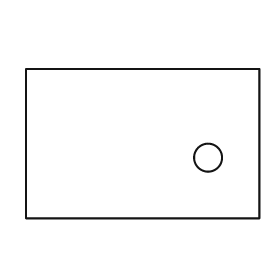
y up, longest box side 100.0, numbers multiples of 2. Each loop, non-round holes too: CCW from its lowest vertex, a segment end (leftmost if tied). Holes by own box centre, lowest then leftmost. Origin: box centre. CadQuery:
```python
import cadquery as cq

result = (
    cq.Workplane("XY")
    .moveTo(-50.0, -32.0)
    .lineTo(50.0, -32.0)
    .lineTo(50.0, 32.0)
    .lineTo(-50.0, 32.0)
    .close()
    .moveTo(28.0, -6.0)
    .circle(6.0)
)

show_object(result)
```